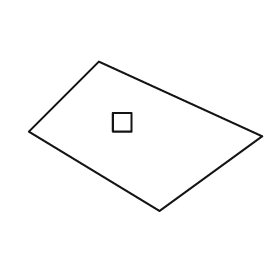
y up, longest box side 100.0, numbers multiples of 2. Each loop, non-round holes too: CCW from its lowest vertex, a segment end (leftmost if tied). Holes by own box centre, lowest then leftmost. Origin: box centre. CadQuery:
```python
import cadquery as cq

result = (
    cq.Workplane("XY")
    .moveTo(6.0, -32.0)
    .lineTo(50.0, 0.0)
    .lineTo(-20.0, 32.0)
    .lineTo(-50.0, 2.0)
    .close()
    .moveTo(-14.0, 2.0)
    .lineTo(-6.0, 2.0)
    .lineTo(-6.0, 10.0)
    .lineTo(-14.0, 10.0)
    .close()
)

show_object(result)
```